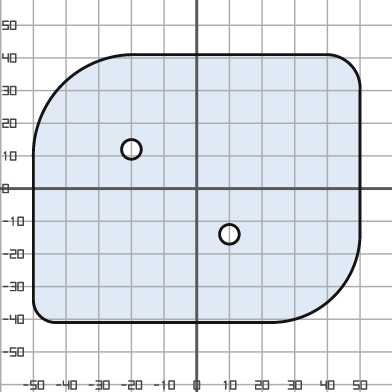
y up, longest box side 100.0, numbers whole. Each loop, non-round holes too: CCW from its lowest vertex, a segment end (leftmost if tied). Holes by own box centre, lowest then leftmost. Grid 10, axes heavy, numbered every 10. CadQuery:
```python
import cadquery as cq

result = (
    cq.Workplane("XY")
    .moveTo(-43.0, -41.0)
    .lineTo(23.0, -41.0)
    .threePointArc((42.0, -33.0), (50.0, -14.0))
    .lineTo(50.0, 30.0)
    .threePointArc((47.0, 38.0), (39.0, 41.0))
    .lineTo(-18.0, 41.0)
    .threePointArc((-41.0, 32.0), (-50.0, 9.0))
    .lineTo(-50.0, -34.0)
    .threePointArc((-48.0, -39.0), (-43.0, -41.0))
    .close()
    .moveTo(10.0, -14.0)
    .circle(3.0)
    .moveTo(-20.0, 12.0)
    .circle(3.0)
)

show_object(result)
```